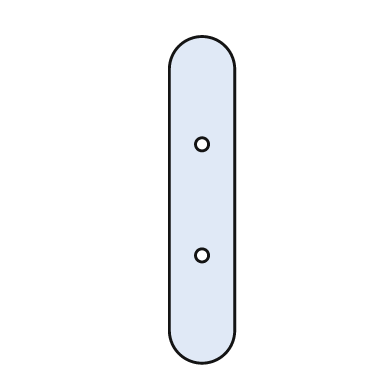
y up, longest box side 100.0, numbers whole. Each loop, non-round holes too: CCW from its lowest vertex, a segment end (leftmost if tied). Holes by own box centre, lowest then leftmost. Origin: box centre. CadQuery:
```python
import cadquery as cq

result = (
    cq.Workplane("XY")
    .moveTo(-10.0, -40.0)
    .threePointArc((0.0, -50.0), (10.0, -40.0))
    .lineTo(10.0, 40.0)
    .threePointArc((0.0, 50.0), (-10.0, 40.0))
    .close()
    .moveTo(0.0, -17.0)
    .circle(2.0)
    .moveTo(0.0, 17.0)
    .circle(2.0)
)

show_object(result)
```